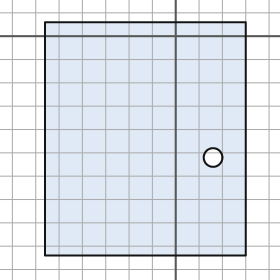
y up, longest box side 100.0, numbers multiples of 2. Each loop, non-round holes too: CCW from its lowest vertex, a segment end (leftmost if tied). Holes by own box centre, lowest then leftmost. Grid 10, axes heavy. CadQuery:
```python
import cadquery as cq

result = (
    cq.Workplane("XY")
    .moveTo(-56.0, -94.0)
    .lineTo(30.0, -94.0)
    .lineTo(30.0, 6.0)
    .lineTo(-56.0, 6.0)
    .close()
    .moveTo(16.0, -52.0)
    .circle(4.0)
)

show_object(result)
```